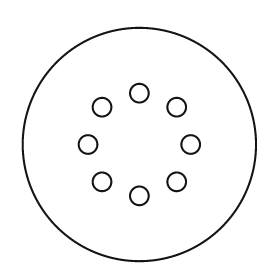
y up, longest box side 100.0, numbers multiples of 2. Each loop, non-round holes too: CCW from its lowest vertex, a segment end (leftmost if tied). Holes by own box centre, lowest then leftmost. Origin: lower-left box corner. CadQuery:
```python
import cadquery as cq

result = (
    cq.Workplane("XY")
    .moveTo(50.0, 50.0)
    .circle(50.0)
    .moveTo(50.0, 28.0)
    .circle(4.0)
    .moveTo(34.0, 34.0)
    .circle(4.0)
    .moveTo(66.0, 34.0)
    .circle(4.0)
    .moveTo(28.0, 50.0)
    .circle(4.0)
    .moveTo(72.0, 50.0)
    .circle(4.0)
    .moveTo(34.0, 66.0)
    .circle(4.0)
    .moveTo(66.0, 66.0)
    .circle(4.0)
    .moveTo(50.0, 72.0)
    .circle(4.0)
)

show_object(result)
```